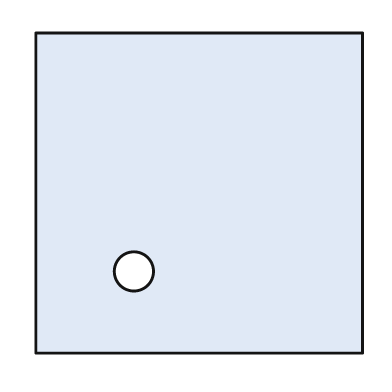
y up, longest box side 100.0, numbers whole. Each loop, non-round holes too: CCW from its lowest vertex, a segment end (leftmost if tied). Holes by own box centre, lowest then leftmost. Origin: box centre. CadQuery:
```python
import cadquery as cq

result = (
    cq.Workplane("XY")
    .moveTo(-50.0, -49.0)
    .lineTo(50.0, -49.0)
    .lineTo(50.0, 49.0)
    .lineTo(-50.0, 49.0)
    .close()
    .moveTo(-20.0, -24.0)
    .circle(6.0)
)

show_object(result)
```